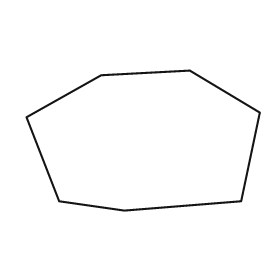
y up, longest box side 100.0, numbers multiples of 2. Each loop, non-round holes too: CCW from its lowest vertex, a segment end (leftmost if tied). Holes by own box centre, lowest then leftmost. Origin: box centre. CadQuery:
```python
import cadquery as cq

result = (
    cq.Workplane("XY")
    .moveTo(-8.0, -30.0)
    .lineTo(42.0, -26.0)
    .lineTo(50.0, 12.0)
    .lineTo(20.0, 30.0)
    .lineTo(-18.0, 28.0)
    .lineTo(-50.0, 10.0)
    .lineTo(-36.0, -26.0)
    .close()
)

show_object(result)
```